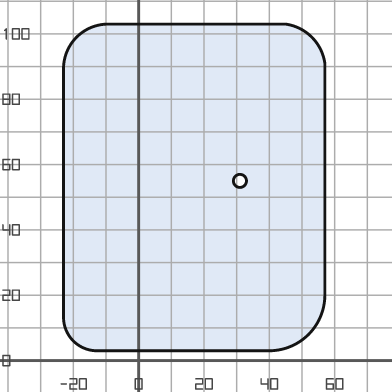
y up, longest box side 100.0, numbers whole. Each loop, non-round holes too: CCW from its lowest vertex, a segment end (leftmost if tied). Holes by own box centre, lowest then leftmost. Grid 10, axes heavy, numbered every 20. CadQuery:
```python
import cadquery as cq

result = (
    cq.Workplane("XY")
    .moveTo(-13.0, 3.0)
    .lineTo(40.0, 3.0)
    .threePointArc((52.0, 8.0), (57.0, 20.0))
    .lineTo(57.0, 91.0)
    .threePointArc((53.0, 99.0), (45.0, 103.0))
    .lineTo(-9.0, 103.0)
    .threePointArc((-19.0, 99.0), (-23.0, 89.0))
    .lineTo(-23.0, 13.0)
    .threePointArc((-20.0, 6.0), (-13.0, 3.0))
    .close()
    .moveTo(31.0, 55.0)
    .circle(2.0)
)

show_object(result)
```